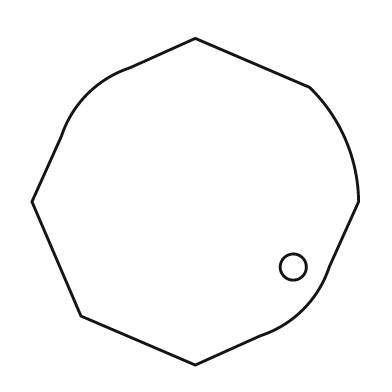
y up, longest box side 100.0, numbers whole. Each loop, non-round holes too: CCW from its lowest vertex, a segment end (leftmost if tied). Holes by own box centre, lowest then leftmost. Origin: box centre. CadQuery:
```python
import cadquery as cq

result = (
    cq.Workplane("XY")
    .moveTo(0.0, -50.0)
    .lineTo(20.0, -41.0)
    .threePointArc((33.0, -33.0), (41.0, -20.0))
    .lineTo(50.0, 0.0)
    .threePointArc((46.0, 19.0), (35.0, 35.0))
    .lineTo(0.0, 50.0)
    .lineTo(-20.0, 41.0)
    .threePointArc((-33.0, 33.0), (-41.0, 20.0))
    .lineTo(-50.0, 0.0)
    .lineTo(-35.0, -35.0)
    .close()
    .moveTo(30.0, -20.0)
    .circle(4.0)
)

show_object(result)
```